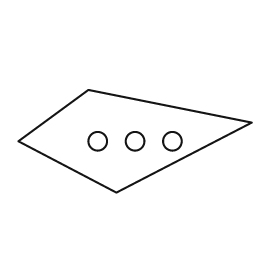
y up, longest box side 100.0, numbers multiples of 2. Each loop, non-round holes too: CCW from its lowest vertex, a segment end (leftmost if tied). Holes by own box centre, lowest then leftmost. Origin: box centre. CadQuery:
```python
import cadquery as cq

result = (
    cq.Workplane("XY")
    .moveTo(-8.0, -22.0)
    .lineTo(50.0, 8.0)
    .lineTo(-20.0, 22.0)
    .lineTo(-50.0, 0.0)
    .close()
    .moveTo(-16.0, 0.0)
    .circle(4.0)
    .moveTo(0.0, 0.0)
    .circle(4.0)
    .moveTo(16.0, 0.0)
    .circle(4.0)
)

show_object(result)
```